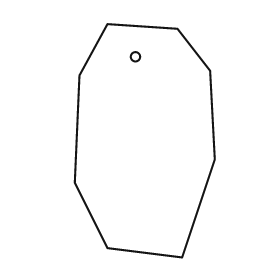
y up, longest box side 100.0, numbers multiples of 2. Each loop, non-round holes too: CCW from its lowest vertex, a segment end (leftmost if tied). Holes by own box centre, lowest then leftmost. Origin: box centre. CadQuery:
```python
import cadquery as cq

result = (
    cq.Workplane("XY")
    .moveTo(16.0, -50.0)
    .lineTo(30.0, -8.0)
    .lineTo(28.0, 30.0)
    .lineTo(14.0, 48.0)
    .lineTo(-16.0, 50.0)
    .lineTo(-28.0, 28.0)
    .lineTo(-30.0, -18.0)
    .lineTo(-16.0, -46.0)
    .close()
    .moveTo(-4.0, 36.0)
    .circle(2.0)
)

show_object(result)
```